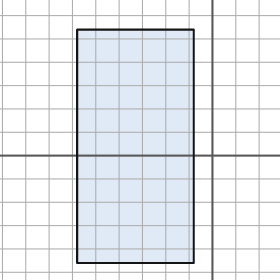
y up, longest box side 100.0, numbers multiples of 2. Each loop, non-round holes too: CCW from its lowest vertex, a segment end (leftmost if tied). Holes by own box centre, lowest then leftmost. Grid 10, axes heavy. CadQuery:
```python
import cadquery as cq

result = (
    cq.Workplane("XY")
    .moveTo(-58.0, -46.0)
    .lineTo(-8.0, -46.0)
    .lineTo(-8.0, 54.0)
    .lineTo(-58.0, 54.0)
    .close()
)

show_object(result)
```